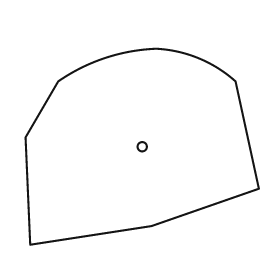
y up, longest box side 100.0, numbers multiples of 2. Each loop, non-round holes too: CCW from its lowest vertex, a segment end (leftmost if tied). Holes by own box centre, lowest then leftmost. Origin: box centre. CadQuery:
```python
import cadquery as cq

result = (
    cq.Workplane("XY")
    .moveTo(-48.0, -42.0)
    .lineTo(4.0, -34.0)
    .lineTo(50.0, -18.0)
    .lineTo(40.0, 28.0)
    .threePointArc((24.0, 38.0), (6.0, 42.0))
    .threePointArc((-16.0, 38.0), (-36.0, 28.0))
    .lineTo(-50.0, 4.0)
    .close()
    .moveTo(0.0, 0.0)
    .circle(2.0)
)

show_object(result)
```